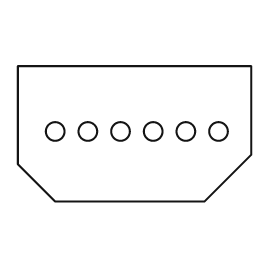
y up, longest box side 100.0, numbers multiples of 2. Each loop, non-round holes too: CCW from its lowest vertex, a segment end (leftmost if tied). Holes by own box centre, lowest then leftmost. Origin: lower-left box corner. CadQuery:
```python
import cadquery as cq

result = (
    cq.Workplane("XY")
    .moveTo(16.0, 0.0)
    .lineTo(80.0, 0.0)
    .lineTo(100.0, 20.0)
    .lineTo(100.0, 58.0)
    .lineTo(0.0, 58.0)
    .lineTo(0.0, 16.0)
    .close()
    .moveTo(16.0, 30.0)
    .circle(4.0)
    .moveTo(30.0, 30.0)
    .circle(4.0)
    .moveTo(44.0, 30.0)
    .circle(4.0)
    .moveTo(58.0, 30.0)
    .circle(4.0)
    .moveTo(72.0, 30.0)
    .circle(4.0)
    .moveTo(86.0, 30.0)
    .circle(4.0)
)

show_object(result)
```